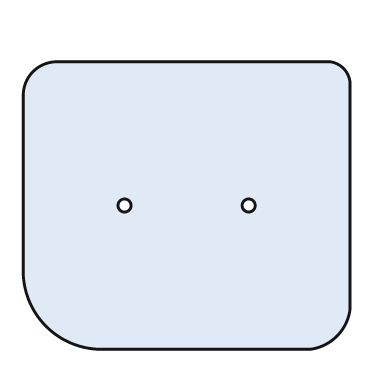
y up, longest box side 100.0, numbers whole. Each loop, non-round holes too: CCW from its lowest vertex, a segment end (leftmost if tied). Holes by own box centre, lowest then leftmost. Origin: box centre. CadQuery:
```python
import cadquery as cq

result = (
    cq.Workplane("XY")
    .moveTo(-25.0, -44.0)
    .lineTo(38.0, -44.0)
    .threePointArc((46.0, -40.0), (50.0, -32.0))
    .lineTo(50.0, 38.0)
    .threePointArc((48.0, 42.0), (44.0, 44.0))
    .lineTo(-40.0, 44.0)
    .threePointArc((-47.0, 41.0), (-50.0, 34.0))
    .lineTo(-50.0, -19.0)
    .threePointArc((-43.0, -37.0), (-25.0, -44.0))
    .close()
    .moveTo(-19.0, 0.0)
    .circle(2.0)
    .moveTo(19.0, 0.0)
    .circle(2.0)
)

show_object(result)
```